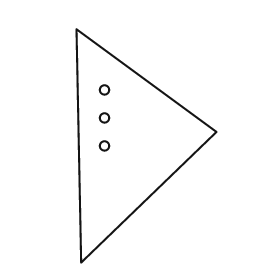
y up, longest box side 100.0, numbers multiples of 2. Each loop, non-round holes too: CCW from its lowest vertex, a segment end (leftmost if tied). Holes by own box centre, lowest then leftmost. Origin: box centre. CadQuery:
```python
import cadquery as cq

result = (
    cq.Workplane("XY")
    .moveTo(-28.0, -50.0)
    .lineTo(30.0, 6.0)
    .lineTo(-30.0, 50.0)
    .close()
    .moveTo(-18.0, 0.0)
    .circle(2.0)
    .moveTo(-18.0, 12.0)
    .circle(2.0)
    .moveTo(-18.0, 24.0)
    .circle(2.0)
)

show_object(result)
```